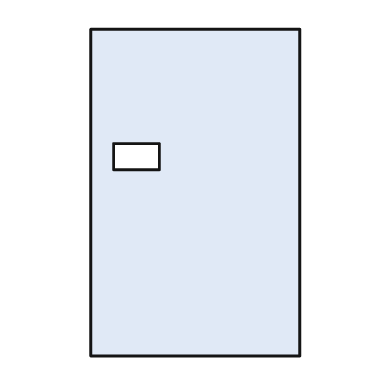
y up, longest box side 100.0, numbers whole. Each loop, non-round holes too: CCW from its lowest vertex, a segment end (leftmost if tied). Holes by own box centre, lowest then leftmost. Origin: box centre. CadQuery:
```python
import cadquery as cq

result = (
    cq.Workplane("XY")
    .moveTo(-32.0, -50.0)
    .lineTo(32.0, -50.0)
    .lineTo(32.0, 50.0)
    .lineTo(-32.0, 50.0)
    .close()
    .moveTo(-25.0, 7.0)
    .lineTo(-11.0, 7.0)
    .lineTo(-11.0, 15.0)
    .lineTo(-25.0, 15.0)
    .close()
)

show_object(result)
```